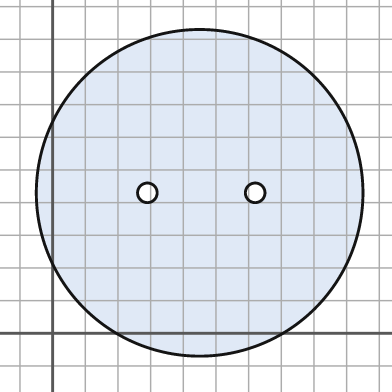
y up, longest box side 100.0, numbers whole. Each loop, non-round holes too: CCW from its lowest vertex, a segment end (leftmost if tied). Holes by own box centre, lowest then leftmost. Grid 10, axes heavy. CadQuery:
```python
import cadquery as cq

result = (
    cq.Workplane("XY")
    .moveTo(45.0, 43.0)
    .circle(50.0)
    .moveTo(29.0, 43.0)
    .circle(3.0)
    .moveTo(62.0, 43.0)
    .circle(3.0)
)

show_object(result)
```